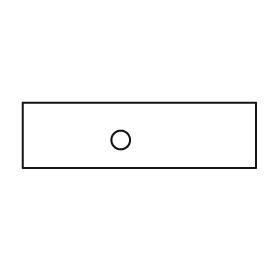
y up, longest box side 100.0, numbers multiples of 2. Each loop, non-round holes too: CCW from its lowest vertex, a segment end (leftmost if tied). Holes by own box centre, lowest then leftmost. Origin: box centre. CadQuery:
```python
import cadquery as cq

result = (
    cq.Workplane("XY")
    .moveTo(-50.0, -14.0)
    .lineTo(50.0, -14.0)
    .lineTo(50.0, 14.0)
    .lineTo(-50.0, 14.0)
    .close()
    .moveTo(-8.0, -2.0)
    .circle(4.0)
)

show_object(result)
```